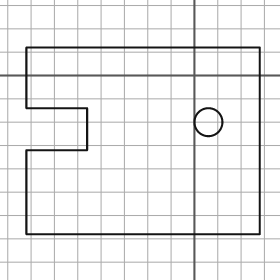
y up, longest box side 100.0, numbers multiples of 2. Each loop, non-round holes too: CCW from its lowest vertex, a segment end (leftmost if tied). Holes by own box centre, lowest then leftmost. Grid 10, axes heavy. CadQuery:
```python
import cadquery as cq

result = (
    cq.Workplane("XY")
    .moveTo(-72.0, -68.0)
    .lineTo(28.0, -68.0)
    .lineTo(28.0, 12.0)
    .lineTo(-72.0, 12.0)
    .lineTo(-72.0, -14.0)
    .lineTo(-46.0, -14.0)
    .lineTo(-46.0, -32.0)
    .lineTo(-72.0, -32.0)
    .close()
    .moveTo(6.0, -20.0)
    .circle(6.0)
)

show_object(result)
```